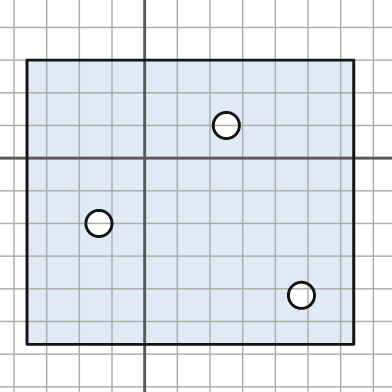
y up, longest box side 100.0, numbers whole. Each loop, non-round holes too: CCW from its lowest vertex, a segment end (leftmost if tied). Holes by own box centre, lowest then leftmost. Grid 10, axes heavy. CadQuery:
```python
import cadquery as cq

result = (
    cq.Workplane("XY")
    .moveTo(-36.0, -57.0)
    .lineTo(64.0, -57.0)
    .lineTo(64.0, 30.0)
    .lineTo(-36.0, 30.0)
    .close()
    .moveTo(48.0, -42.0)
    .circle(4.0)
    .moveTo(-14.0, -20.0)
    .circle(4.0)
    .moveTo(25.0, 10.0)
    .circle(4.0)
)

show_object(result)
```